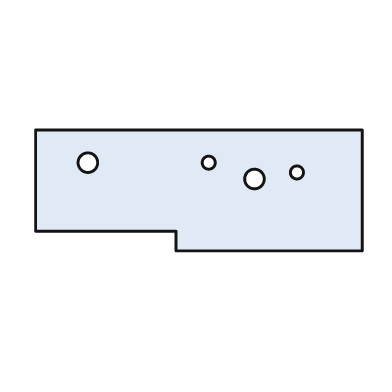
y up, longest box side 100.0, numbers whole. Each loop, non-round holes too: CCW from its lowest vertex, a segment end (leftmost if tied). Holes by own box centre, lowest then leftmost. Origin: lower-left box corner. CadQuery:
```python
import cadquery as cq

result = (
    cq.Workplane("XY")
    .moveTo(43.0, 0.0)
    .lineTo(100.0, 0.0)
    .lineTo(100.0, 37.0)
    .lineTo(0.0, 37.0)
    .lineTo(0.0, 6.0)
    .lineTo(43.0, 6.0)
    .close()
    .moveTo(67.0, 22.0)
    .circle(3.0)
    .moveTo(80.0, 24.0)
    .circle(2.0)
    .moveTo(16.0, 27.0)
    .circle(3.0)
    .moveTo(53.0, 27.0)
    .circle(2.0)
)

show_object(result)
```